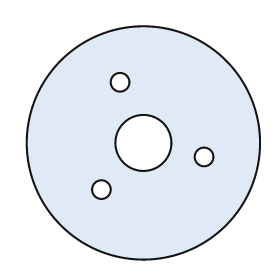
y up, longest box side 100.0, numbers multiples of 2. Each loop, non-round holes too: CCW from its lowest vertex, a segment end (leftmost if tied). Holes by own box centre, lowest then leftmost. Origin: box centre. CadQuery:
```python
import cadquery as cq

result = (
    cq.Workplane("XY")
    .moveTo(0.0, 0.0)
    .circle(50.0)
    .moveTo(-18.0, -20.0)
    .circle(4.0)
    .moveTo(26.0, -6.0)
    .circle(4.0)
    .moveTo(0.0, 0.0)
    .circle(12.0)
    .moveTo(-10.0, 26.0)
    .circle(4.0)
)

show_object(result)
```